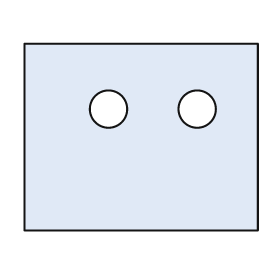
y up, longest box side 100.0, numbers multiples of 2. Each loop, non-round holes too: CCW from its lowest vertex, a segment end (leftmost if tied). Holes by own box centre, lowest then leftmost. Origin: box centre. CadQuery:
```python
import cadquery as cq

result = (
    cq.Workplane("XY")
    .moveTo(-50.0, -40.0)
    .lineTo(50.0, -40.0)
    .lineTo(50.0, 40.0)
    .lineTo(-50.0, 40.0)
    .close()
    .moveTo(-14.0, 12.0)
    .circle(8.0)
    .moveTo(24.0, 12.0)
    .circle(8.0)
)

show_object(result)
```